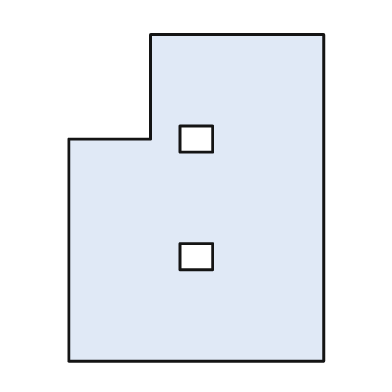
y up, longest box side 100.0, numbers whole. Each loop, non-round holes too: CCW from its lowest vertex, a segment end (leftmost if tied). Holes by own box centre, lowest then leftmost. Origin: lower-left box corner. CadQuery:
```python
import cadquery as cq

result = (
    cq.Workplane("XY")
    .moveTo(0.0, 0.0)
    .lineTo(78.0, 0.0)
    .lineTo(78.0, 100.0)
    .lineTo(25.0, 100.0)
    .lineTo(25.0, 68.0)
    .lineTo(0.0, 68.0)
    .close()
    .moveTo(34.0, 28.0)
    .lineTo(44.0, 28.0)
    .lineTo(44.0, 36.0)
    .lineTo(34.0, 36.0)
    .close()
    .moveTo(34.0, 64.0)
    .lineTo(44.0, 64.0)
    .lineTo(44.0, 72.0)
    .lineTo(34.0, 72.0)
    .close()
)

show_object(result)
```